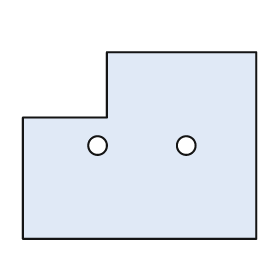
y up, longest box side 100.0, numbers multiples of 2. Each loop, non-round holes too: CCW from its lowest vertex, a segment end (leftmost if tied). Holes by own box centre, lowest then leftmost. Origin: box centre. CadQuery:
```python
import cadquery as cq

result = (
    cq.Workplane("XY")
    .moveTo(-50.0, -40.0)
    .lineTo(50.0, -40.0)
    .lineTo(50.0, 40.0)
    .lineTo(-14.0, 40.0)
    .lineTo(-14.0, 12.0)
    .lineTo(-50.0, 12.0)
    .close()
    .moveTo(-18.0, 0.0)
    .circle(4.0)
    .moveTo(20.0, 0.0)
    .circle(4.0)
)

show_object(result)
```